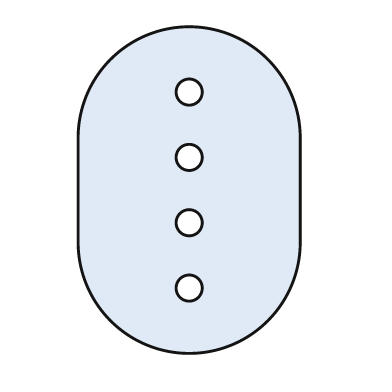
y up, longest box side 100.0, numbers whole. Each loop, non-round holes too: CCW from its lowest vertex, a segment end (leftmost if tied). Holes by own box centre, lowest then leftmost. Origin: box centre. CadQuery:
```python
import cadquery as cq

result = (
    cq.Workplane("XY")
    .moveTo(-34.0, -16.0)
    .threePointArc((0.0, -50.0), (34.0, -16.0))
    .lineTo(34.0, 16.0)
    .threePointArc((0.0, 50.0), (-34.0, 16.0))
    .close()
    .moveTo(0.0, -30.0)
    .circle(4.0)
    .moveTo(0.0, -10.0)
    .circle(4.0)
    .moveTo(0.0, 10.0)
    .circle(4.0)
    .moveTo(0.0, 30.0)
    .circle(4.0)
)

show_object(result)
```